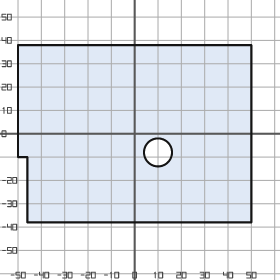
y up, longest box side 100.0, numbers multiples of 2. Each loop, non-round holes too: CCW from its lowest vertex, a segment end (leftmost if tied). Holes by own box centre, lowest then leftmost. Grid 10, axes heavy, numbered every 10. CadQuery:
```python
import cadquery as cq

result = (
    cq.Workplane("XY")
    .moveTo(-46.0, -38.0)
    .lineTo(50.0, -38.0)
    .lineTo(50.0, 38.0)
    .lineTo(-50.0, 38.0)
    .lineTo(-50.0, -10.0)
    .lineTo(-46.0, -10.0)
    .close()
    .moveTo(10.0, -8.0)
    .circle(6.0)
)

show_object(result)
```